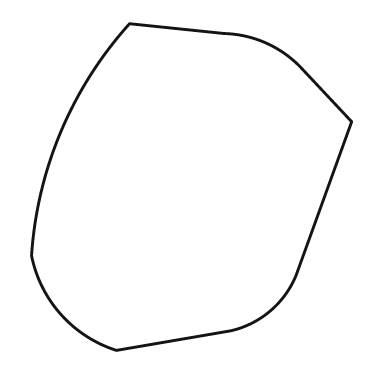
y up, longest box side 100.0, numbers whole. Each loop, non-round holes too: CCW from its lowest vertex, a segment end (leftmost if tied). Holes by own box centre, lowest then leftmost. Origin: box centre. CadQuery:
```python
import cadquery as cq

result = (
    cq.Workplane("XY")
    .moveTo(-23.0, -50.0)
    .lineTo(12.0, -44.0)
    .threePointArc((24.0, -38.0), (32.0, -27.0))
    .lineTo(49.0, 20.0)
    .lineTo(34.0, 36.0)
    .threePointArc((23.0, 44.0), (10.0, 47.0))
    .lineTo(-19.0, 50.0)
    .threePointArc((-40.0, 17.0), (-49.0, -21.0))
    .threePointArc((-40.0, -39.0), (-23.0, -50.0))
    .close()
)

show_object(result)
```